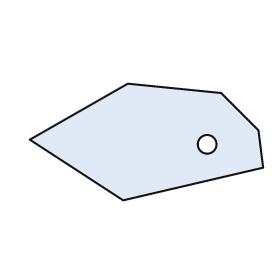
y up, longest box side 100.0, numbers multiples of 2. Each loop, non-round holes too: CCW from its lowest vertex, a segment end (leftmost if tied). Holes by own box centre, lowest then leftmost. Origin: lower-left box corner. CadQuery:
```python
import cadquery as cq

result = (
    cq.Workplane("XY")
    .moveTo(40.0, 0.0)
    .lineTo(100.0, 14.0)
    .lineTo(98.0, 30.0)
    .lineTo(82.0, 46.0)
    .lineTo(42.0, 50.0)
    .lineTo(0.0, 26.0)
    .close()
    .moveTo(76.0, 24.0)
    .circle(4.0)
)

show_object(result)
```